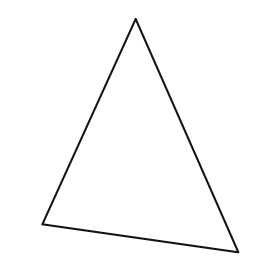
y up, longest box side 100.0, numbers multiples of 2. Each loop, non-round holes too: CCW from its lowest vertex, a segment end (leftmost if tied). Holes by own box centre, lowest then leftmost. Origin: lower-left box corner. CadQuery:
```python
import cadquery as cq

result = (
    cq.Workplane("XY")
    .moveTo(84.0, 0.0)
    .lineTo(40.0, 100.0)
    .lineTo(0.0, 12.0)
    .close()
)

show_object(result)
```